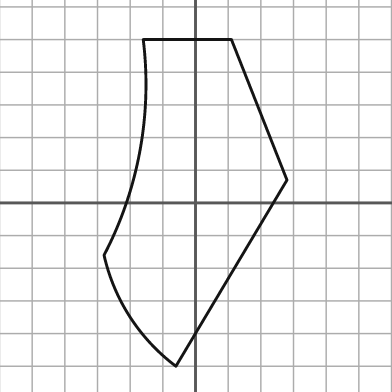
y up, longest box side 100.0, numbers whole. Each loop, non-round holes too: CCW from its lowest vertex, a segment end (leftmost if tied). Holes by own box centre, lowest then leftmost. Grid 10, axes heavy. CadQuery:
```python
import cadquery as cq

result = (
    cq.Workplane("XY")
    .moveTo(-6.0, -50.0)
    .lineTo(28.0, 7.0)
    .lineTo(11.0, 50.0)
    .lineTo(-16.0, 50.0)
    .threePointArc((-17.0, 16.0), (-28.0, -16.0))
    .threePointArc((-20.0, -35.0), (-6.0, -50.0))
    .close()
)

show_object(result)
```